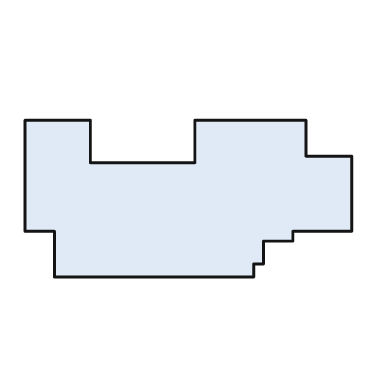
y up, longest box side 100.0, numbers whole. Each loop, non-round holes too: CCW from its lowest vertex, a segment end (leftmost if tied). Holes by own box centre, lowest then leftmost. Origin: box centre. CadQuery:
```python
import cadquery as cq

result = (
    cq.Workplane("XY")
    .moveTo(-41.0, -24.0)
    .lineTo(20.0, -24.0)
    .lineTo(20.0, -20.0)
    .lineTo(23.0, -20.0)
    .lineTo(23.0, -13.0)
    .lineTo(32.0, -13.0)
    .lineTo(32.0, -10.0)
    .lineTo(50.0, -10.0)
    .lineTo(50.0, 13.0)
    .lineTo(36.0, 13.0)
    .lineTo(36.0, 24.0)
    .lineTo(2.0, 24.0)
    .lineTo(2.0, 11.0)
    .lineTo(-30.0, 11.0)
    .lineTo(-30.0, 24.0)
    .lineTo(-50.0, 24.0)
    .lineTo(-50.0, -10.0)
    .lineTo(-41.0, -10.0)
    .close()
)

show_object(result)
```